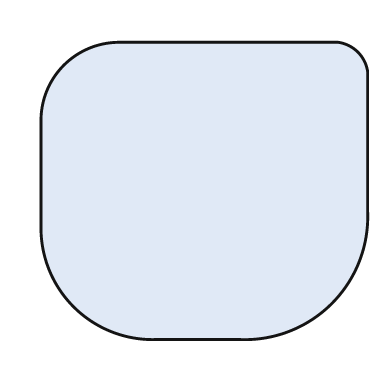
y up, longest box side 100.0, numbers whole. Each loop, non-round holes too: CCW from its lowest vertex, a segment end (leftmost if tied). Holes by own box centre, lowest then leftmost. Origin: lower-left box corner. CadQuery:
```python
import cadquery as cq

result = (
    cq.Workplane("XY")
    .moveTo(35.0, 0.0)
    .lineTo(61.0, 0.0)
    .threePointArc((89.0, 11.0), (100.0, 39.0))
    .lineTo(100.0, 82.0)
    .threePointArc((97.0, 88.0), (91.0, 91.0))
    .lineTo(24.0, 91.0)
    .threePointArc((7.0, 84.0), (0.0, 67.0))
    .lineTo(0.0, 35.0)
    .threePointArc((10.0, 10.0), (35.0, 0.0))
    .close()
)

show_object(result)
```